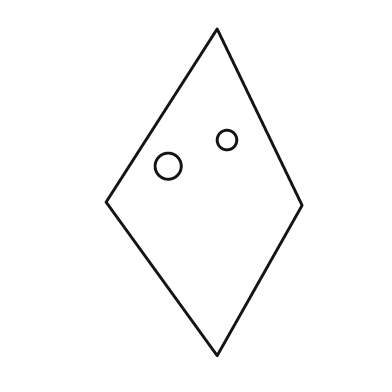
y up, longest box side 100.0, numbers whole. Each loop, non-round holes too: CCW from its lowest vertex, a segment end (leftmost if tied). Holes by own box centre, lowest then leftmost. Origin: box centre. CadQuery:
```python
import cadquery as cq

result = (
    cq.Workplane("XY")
    .moveTo(4.0, -50.0)
    .lineTo(30.0, -4.0)
    .lineTo(4.0, 50.0)
    .lineTo(-30.0, -3.0)
    .close()
    .moveTo(-11.0, 8.0)
    .circle(4.0)
    .moveTo(7.0, 16.0)
    .circle(3.0)
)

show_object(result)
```